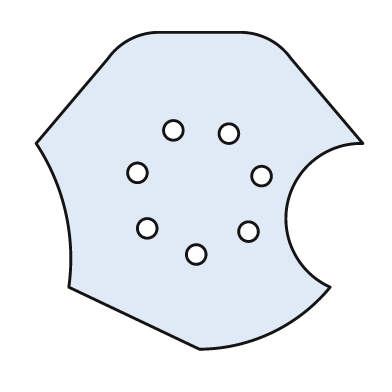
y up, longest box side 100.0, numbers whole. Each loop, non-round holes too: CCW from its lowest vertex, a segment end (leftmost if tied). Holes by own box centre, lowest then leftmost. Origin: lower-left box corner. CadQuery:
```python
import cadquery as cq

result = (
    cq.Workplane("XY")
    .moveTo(50.0, 0.0)
    .threePointArc((72.0, 5.0), (90.0, 19.0))
    .threePointArc((77.0, 45.0), (100.0, 63.0))
    .lineTo(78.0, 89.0)
    .threePointArc((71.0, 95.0), (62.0, 97.0))
    .lineTo(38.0, 97.0)
    .threePointArc((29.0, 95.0), (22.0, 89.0))
    .lineTo(0.0, 63.0)
    .threePointArc((9.0, 42.0), (10.0, 19.0))
    .close()
    .moveTo(49.0, 29.0)
    .circle(3.0)
    .moveTo(65.0, 36.0)
    .circle(3.0)
    .moveTo(34.0, 37.0)
    .circle(3.0)
    .moveTo(69.0, 53.0)
    .circle(3.0)
    .moveTo(31.0, 54.0)
    .circle(3.0)
    .moveTo(59.0, 66.0)
    .circle(3.0)
    .moveTo(42.0, 67.0)
    .circle(3.0)
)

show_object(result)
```